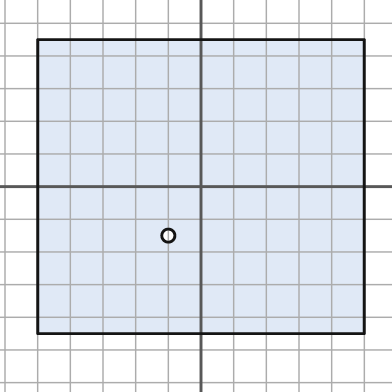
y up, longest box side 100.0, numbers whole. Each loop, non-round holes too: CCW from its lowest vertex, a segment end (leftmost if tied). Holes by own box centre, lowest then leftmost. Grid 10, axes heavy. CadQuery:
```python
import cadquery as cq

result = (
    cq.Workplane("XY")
    .moveTo(-50.0, -45.0)
    .lineTo(50.0, -45.0)
    .lineTo(50.0, 45.0)
    .lineTo(-50.0, 45.0)
    .close()
    .moveTo(-10.0, -15.0)
    .circle(2.0)
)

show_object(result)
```